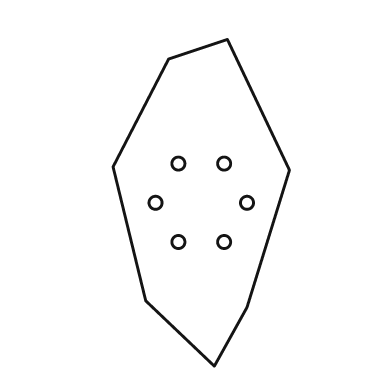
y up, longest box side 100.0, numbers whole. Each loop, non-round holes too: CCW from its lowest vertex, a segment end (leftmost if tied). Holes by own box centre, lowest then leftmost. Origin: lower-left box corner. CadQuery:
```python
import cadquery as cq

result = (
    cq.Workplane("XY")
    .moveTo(31.0, 0.0)
    .lineTo(41.0, 18.0)
    .lineTo(54.0, 60.0)
    .lineTo(35.0, 100.0)
    .lineTo(17.0, 94.0)
    .lineTo(0.0, 61.0)
    .lineTo(10.0, 20.0)
    .close()
    .moveTo(20.0, 38.0)
    .circle(2.0)
    .moveTo(34.0, 38.0)
    .circle(2.0)
    .moveTo(13.0, 50.0)
    .circle(2.0)
    .moveTo(41.0, 50.0)
    .circle(2.0)
    .moveTo(20.0, 62.0)
    .circle(2.0)
    .moveTo(34.0, 62.0)
    .circle(2.0)
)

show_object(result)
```